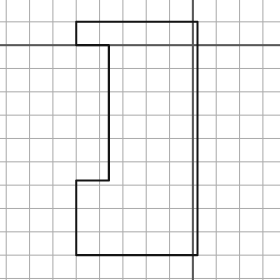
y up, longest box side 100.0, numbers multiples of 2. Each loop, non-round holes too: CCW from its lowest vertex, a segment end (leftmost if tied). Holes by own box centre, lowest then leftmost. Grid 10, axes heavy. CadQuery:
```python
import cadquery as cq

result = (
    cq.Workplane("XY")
    .moveTo(-50.0, -90.0)
    .lineTo(2.0, -90.0)
    .lineTo(2.0, 10.0)
    .lineTo(-50.0, 10.0)
    .lineTo(-50.0, 0.0)
    .lineTo(-36.0, 0.0)
    .lineTo(-36.0, -58.0)
    .lineTo(-50.0, -58.0)
    .close()
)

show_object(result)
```